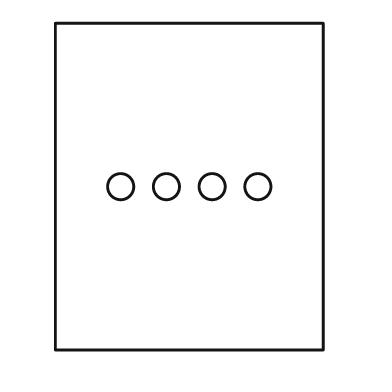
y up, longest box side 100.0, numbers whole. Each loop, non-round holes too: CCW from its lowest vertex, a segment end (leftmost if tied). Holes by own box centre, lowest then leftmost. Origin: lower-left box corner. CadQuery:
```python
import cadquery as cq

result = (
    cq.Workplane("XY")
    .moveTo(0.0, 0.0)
    .lineTo(82.0, 0.0)
    .lineTo(82.0, 100.0)
    .lineTo(0.0, 100.0)
    .close()
    .moveTo(20.0, 50.0)
    .circle(4.0)
    .moveTo(34.0, 50.0)
    .circle(4.0)
    .moveTo(48.0, 50.0)
    .circle(4.0)
    .moveTo(62.0, 50.0)
    .circle(4.0)
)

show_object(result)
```